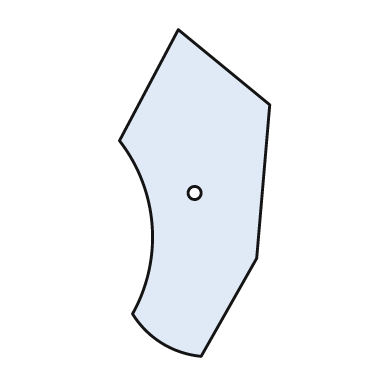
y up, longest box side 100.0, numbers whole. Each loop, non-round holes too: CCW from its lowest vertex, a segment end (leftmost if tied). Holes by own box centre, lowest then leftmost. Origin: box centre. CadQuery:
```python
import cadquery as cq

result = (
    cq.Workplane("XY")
    .moveTo(2.0, -50.0)
    .lineTo(19.0, -20.0)
    .lineTo(23.0, 27.0)
    .lineTo(-5.0, 50.0)
    .lineTo(-23.0, 16.0)
    .threePointArc((-13.0, -10.0), (-19.0, -37.0))
    .threePointArc((-10.0, -46.0), (2.0, -50.0))
    .close()
    .moveTo(0.0, 0.0)
    .circle(2.0)
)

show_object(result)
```